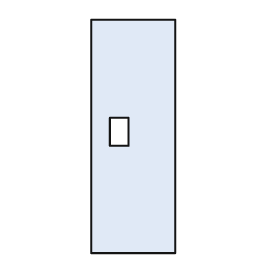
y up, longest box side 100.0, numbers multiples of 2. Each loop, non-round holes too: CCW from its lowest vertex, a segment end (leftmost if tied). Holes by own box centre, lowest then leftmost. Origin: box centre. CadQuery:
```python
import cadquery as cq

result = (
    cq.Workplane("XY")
    .moveTo(-18.0, -50.0)
    .lineTo(18.0, -50.0)
    .lineTo(18.0, 50.0)
    .lineTo(-18.0, 50.0)
    .close()
    .moveTo(-10.0, -4.0)
    .lineTo(-2.0, -4.0)
    .lineTo(-2.0, 8.0)
    .lineTo(-10.0, 8.0)
    .close()
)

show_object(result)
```